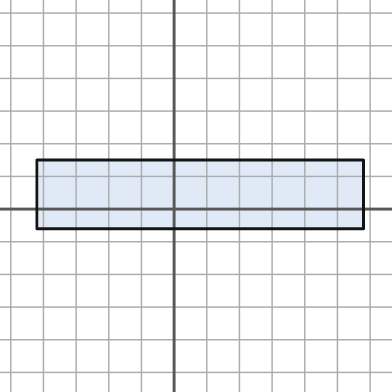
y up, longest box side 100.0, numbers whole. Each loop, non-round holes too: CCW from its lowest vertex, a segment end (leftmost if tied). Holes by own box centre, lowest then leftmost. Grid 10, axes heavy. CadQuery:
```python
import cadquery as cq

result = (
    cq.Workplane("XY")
    .moveTo(-42.0, -6.0)
    .lineTo(58.0, -6.0)
    .lineTo(58.0, 15.0)
    .lineTo(-42.0, 15.0)
    .close()
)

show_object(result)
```